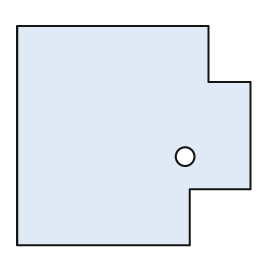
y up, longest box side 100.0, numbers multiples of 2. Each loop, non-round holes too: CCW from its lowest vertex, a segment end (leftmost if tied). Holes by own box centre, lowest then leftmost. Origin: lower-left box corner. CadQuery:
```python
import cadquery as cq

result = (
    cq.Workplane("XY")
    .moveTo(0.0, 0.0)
    .lineTo(74.0, 0.0)
    .lineTo(74.0, 24.0)
    .lineTo(100.0, 24.0)
    .lineTo(100.0, 70.0)
    .lineTo(82.0, 70.0)
    .lineTo(82.0, 94.0)
    .lineTo(0.0, 94.0)
    .close()
    .moveTo(72.0, 38.0)
    .circle(4.0)
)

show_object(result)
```